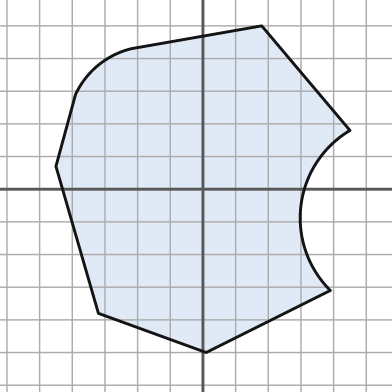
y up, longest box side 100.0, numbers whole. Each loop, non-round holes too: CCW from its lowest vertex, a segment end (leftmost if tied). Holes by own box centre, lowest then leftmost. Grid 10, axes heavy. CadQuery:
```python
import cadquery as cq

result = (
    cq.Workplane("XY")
    .moveTo(1.0, -50.0)
    .lineTo(39.0, -31.0)
    .threePointArc((30.0, -5.0), (45.0, 18.0))
    .lineTo(18.0, 50.0)
    .lineTo(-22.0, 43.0)
    .threePointArc((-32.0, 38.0), (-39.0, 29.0))
    .lineTo(-45.0, 7.0)
    .lineTo(-32.0, -38.0)
    .close()
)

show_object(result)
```